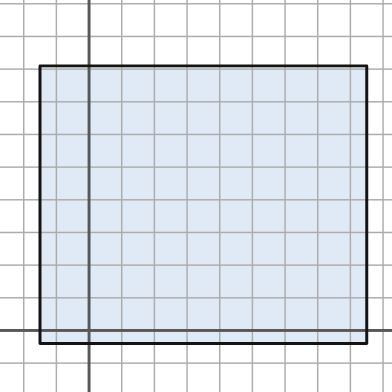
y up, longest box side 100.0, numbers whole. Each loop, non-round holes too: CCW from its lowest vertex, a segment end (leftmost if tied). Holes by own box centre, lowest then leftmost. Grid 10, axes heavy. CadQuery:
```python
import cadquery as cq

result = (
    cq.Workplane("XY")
    .moveTo(-15.0, -4.0)
    .lineTo(85.0, -4.0)
    .lineTo(85.0, 81.0)
    .lineTo(-15.0, 81.0)
    .close()
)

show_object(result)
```